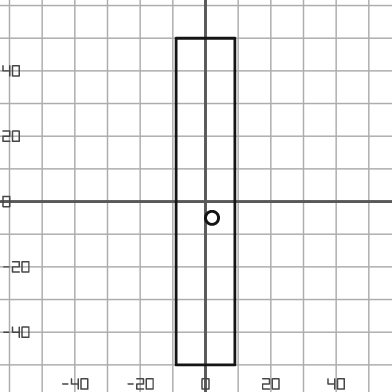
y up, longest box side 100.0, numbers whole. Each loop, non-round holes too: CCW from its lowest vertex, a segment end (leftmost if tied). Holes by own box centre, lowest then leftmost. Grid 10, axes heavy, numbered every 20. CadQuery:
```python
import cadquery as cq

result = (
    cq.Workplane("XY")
    .moveTo(-9.0, -50.0)
    .lineTo(9.0, -50.0)
    .lineTo(9.0, 50.0)
    .lineTo(-9.0, 50.0)
    .close()
    .moveTo(2.0, -5.0)
    .circle(2.0)
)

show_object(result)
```